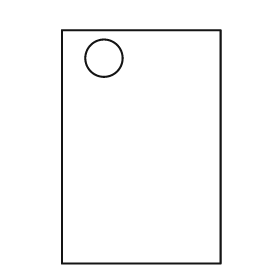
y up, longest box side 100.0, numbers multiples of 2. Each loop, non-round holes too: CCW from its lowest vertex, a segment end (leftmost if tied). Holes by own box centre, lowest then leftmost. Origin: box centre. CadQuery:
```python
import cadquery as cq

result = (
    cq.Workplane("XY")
    .moveTo(-34.0, -50.0)
    .lineTo(34.0, -50.0)
    .lineTo(34.0, 50.0)
    .lineTo(-34.0, 50.0)
    .close()
    .moveTo(-16.0, 38.0)
    .circle(8.0)
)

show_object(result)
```